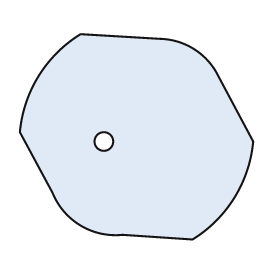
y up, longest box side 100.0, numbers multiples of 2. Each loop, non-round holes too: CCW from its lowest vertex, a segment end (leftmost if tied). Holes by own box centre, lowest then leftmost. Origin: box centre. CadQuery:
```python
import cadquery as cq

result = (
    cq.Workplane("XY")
    .moveTo(24.0, -44.0)
    .threePointArc((42.0, -26.0), (50.0, -2.0))
    .lineTo(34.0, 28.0)
    .threePointArc((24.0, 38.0), (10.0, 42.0))
    .lineTo(-24.0, 44.0)
    .threePointArc((-42.0, 26.0), (-50.0, 2.0))
    .lineTo(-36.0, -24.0)
    .threePointArc((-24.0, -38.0), (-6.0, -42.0))
    .close()
    .moveTo(-14.0, -2.0)
    .circle(4.0)
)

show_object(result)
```